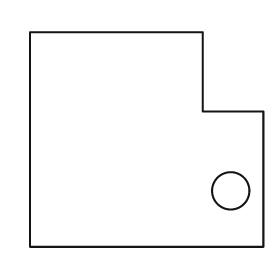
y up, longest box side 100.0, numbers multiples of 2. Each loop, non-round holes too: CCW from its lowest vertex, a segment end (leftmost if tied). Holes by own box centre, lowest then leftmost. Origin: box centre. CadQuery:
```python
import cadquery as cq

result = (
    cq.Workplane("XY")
    .moveTo(-50.0, -46.0)
    .lineTo(50.0, -46.0)
    .lineTo(50.0, 12.0)
    .lineTo(24.0, 12.0)
    .lineTo(24.0, 46.0)
    .lineTo(-50.0, 46.0)
    .close()
    .moveTo(36.0, -22.0)
    .circle(8.0)
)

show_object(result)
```